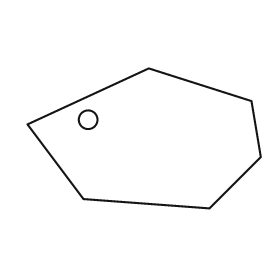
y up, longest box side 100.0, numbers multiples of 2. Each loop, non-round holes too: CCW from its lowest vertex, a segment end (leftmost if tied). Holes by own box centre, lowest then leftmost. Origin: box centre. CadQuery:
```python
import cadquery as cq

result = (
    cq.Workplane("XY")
    .moveTo(28.0, -30.0)
    .lineTo(50.0, -8.0)
    .lineTo(46.0, 16.0)
    .lineTo(2.0, 30.0)
    .lineTo(-50.0, 6.0)
    .lineTo(-26.0, -26.0)
    .close()
    .moveTo(-24.0, 8.0)
    .circle(4.0)
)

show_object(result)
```